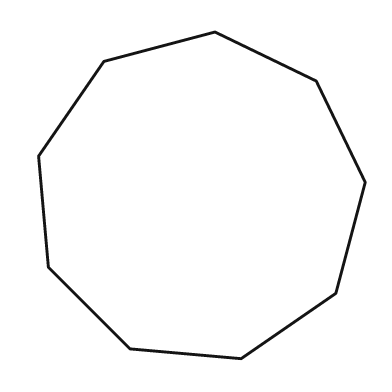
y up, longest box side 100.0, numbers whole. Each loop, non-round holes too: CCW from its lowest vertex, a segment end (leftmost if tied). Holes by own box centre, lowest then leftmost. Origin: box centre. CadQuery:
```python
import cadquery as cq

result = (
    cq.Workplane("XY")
    .moveTo(12.0, -50.0)
    .lineTo(41.0, -30.0)
    .lineTo(50.0, 4.0)
    .lineTo(35.0, 35.0)
    .lineTo(4.0, 50.0)
    .lineTo(-30.0, 41.0)
    .lineTo(-50.0, 12.0)
    .lineTo(-47.0, -22.0)
    .lineTo(-22.0, -47.0)
    .close()
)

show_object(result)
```